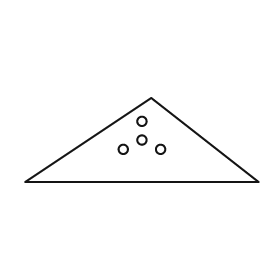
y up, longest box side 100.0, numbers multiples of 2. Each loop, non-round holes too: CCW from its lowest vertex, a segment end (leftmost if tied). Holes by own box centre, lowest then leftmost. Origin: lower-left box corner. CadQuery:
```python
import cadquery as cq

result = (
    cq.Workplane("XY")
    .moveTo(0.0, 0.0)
    .lineTo(100.0, 0.0)
    .lineTo(54.0, 36.0)
    .close()
    .moveTo(42.0, 14.0)
    .circle(2.0)
    .moveTo(58.0, 14.0)
    .circle(2.0)
    .moveTo(50.0, 18.0)
    .circle(2.0)
    .moveTo(50.0, 26.0)
    .circle(2.0)
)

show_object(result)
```